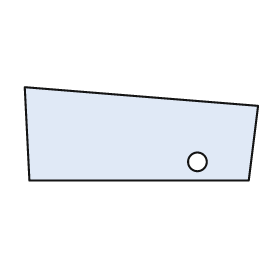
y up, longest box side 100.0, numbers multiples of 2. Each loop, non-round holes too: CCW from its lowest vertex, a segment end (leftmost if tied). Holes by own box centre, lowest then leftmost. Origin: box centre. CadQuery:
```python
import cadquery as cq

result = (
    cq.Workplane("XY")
    .moveTo(-48.0, -20.0)
    .lineTo(46.0, -20.0)
    .lineTo(50.0, 12.0)
    .lineTo(-50.0, 20.0)
    .close()
    .moveTo(24.0, -12.0)
    .circle(4.0)
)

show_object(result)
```